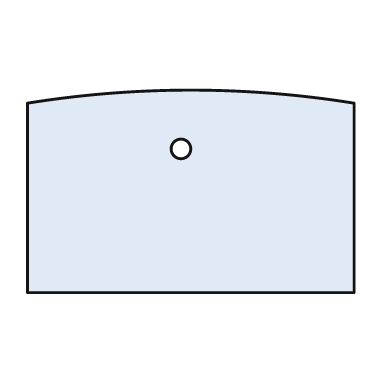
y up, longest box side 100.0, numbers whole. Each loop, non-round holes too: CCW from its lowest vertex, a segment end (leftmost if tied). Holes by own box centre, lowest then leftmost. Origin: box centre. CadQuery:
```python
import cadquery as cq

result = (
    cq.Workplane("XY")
    .moveTo(-50.0, -31.0)
    .lineTo(50.0, -31.0)
    .lineTo(50.0, 27.0)
    .threePointArc((0.0, 31.0), (-50.0, 27.0))
    .close()
    .moveTo(-3.0, 13.0)
    .circle(3.0)
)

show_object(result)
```